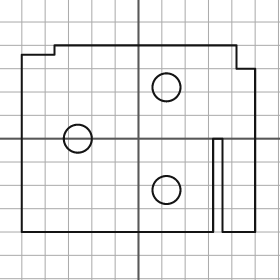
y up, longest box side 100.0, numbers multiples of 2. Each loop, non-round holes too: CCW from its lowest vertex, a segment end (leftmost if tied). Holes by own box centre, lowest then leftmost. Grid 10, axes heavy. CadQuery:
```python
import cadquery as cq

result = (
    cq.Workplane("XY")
    .moveTo(-50.0, -40.0)
    .lineTo(32.0, -40.0)
    .lineTo(32.0, 0.0)
    .lineTo(36.0, 0.0)
    .lineTo(36.0, -40.0)
    .lineTo(50.0, -40.0)
    .lineTo(50.0, 30.0)
    .lineTo(42.0, 30.0)
    .lineTo(42.0, 40.0)
    .lineTo(-36.0, 40.0)
    .lineTo(-36.0, 36.0)
    .lineTo(-50.0, 36.0)
    .close()
    .moveTo(12.0, -22.0)
    .circle(6.0)
    .moveTo(-26.0, 0.0)
    .circle(6.0)
    .moveTo(12.0, 22.0)
    .circle(6.0)
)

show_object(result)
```